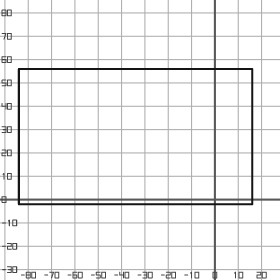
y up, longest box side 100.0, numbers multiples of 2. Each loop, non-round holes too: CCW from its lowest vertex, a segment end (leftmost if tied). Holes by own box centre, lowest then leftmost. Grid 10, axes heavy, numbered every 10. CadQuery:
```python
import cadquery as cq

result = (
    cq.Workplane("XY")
    .moveTo(-84.0, -2.0)
    .lineTo(16.0, -2.0)
    .lineTo(16.0, 56.0)
    .lineTo(-84.0, 56.0)
    .close()
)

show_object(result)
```